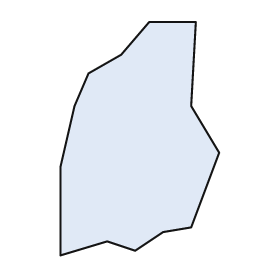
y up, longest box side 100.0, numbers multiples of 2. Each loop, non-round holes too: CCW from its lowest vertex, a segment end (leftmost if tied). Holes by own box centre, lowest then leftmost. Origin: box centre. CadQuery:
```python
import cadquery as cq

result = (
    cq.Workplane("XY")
    .moveTo(-34.0, -50.0)
    .lineTo(-14.0, -44.0)
    .lineTo(-2.0, -48.0)
    .lineTo(10.0, -40.0)
    .lineTo(22.0, -38.0)
    .lineTo(34.0, -6.0)
    .lineTo(22.0, 14.0)
    .lineTo(24.0, 50.0)
    .lineTo(4.0, 50.0)
    .lineTo(-8.0, 36.0)
    .lineTo(-22.0, 28.0)
    .lineTo(-28.0, 14.0)
    .lineTo(-34.0, -12.0)
    .close()
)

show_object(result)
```